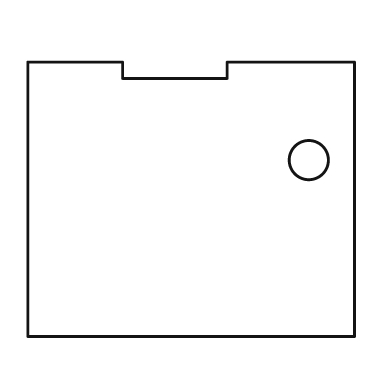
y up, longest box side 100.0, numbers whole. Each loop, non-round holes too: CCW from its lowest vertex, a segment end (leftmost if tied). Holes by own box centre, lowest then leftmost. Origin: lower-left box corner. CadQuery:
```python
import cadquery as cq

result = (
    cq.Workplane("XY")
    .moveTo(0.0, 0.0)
    .lineTo(100.0, 0.0)
    .lineTo(100.0, 84.0)
    .lineTo(61.0, 84.0)
    .lineTo(61.0, 79.0)
    .lineTo(29.0, 79.0)
    .lineTo(29.0, 84.0)
    .lineTo(0.0, 84.0)
    .close()
    .moveTo(86.0, 54.0)
    .circle(6.0)
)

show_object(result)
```